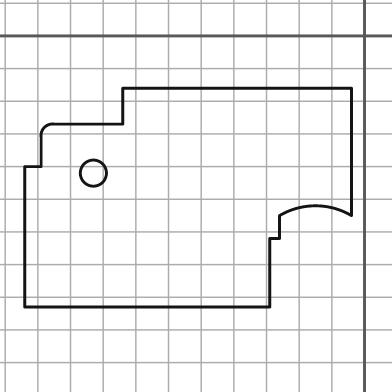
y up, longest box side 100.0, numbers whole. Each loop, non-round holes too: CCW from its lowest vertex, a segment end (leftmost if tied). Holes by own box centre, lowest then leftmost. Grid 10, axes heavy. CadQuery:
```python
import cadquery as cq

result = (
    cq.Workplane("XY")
    .moveTo(-104.0, -83.0)
    .lineTo(-29.0, -83.0)
    .lineTo(-29.0, -62.0)
    .lineTo(-26.0, -62.0)
    .lineTo(-26.0, -55.0)
    .threePointArc((-15.0, -52.0), (-4.0, -55.0))
    .lineTo(-4.0, -16.0)
    .lineTo(-74.0, -16.0)
    .lineTo(-74.0, -27.0)
    .lineTo(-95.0, -27.0)
    .threePointArc((-98.0, -28.0), (-99.0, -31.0))
    .lineTo(-99.0, -40.0)
    .lineTo(-104.0, -40.0)
    .close()
    .moveTo(-83.0, -42.0)
    .circle(4.0)
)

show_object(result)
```